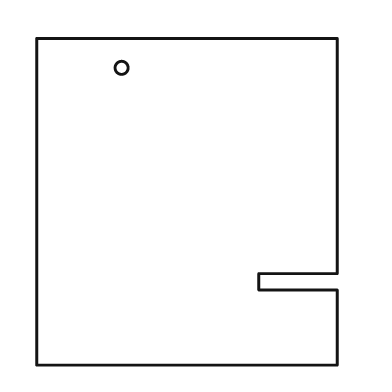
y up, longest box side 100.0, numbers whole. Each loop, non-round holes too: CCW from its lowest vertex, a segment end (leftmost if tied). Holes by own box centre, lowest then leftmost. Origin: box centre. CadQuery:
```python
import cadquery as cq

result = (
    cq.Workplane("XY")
    .moveTo(-46.0, -50.0)
    .lineTo(46.0, -50.0)
    .lineTo(46.0, -27.0)
    .lineTo(22.0, -27.0)
    .lineTo(22.0, -22.0)
    .lineTo(46.0, -22.0)
    .lineTo(46.0, 50.0)
    .lineTo(-46.0, 50.0)
    .close()
    .moveTo(-20.0, 41.0)
    .circle(2.0)
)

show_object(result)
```